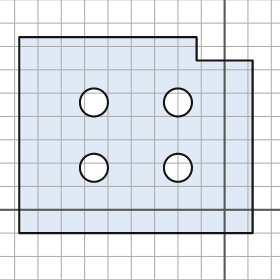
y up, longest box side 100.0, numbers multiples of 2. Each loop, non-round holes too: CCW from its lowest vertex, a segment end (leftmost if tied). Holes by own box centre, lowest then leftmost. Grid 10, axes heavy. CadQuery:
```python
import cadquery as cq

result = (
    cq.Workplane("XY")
    .moveTo(-88.0, -10.0)
    .lineTo(12.0, -10.0)
    .lineTo(12.0, 64.0)
    .lineTo(-12.0, 64.0)
    .lineTo(-12.0, 74.0)
    .lineTo(-88.0, 74.0)
    .close()
    .moveTo(-56.0, 18.0)
    .circle(6.0)
    .moveTo(-20.0, 18.0)
    .circle(6.0)
    .moveTo(-56.0, 46.0)
    .circle(6.0)
    .moveTo(-20.0, 46.0)
    .circle(6.0)
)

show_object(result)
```